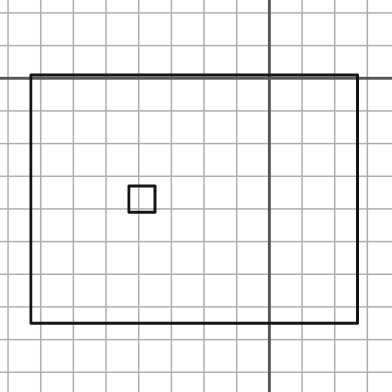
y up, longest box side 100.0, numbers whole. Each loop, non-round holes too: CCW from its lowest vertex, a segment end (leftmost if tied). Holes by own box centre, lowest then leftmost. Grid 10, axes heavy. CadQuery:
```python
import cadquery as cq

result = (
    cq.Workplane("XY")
    .moveTo(-73.0, -75.0)
    .lineTo(27.0, -75.0)
    .lineTo(27.0, 1.0)
    .lineTo(-73.0, 1.0)
    .close()
    .moveTo(-43.0, -41.0)
    .lineTo(-35.0, -41.0)
    .lineTo(-35.0, -33.0)
    .lineTo(-43.0, -33.0)
    .close()
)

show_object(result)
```